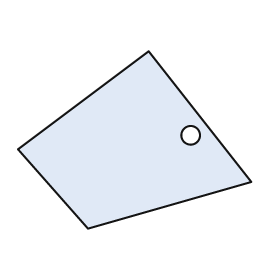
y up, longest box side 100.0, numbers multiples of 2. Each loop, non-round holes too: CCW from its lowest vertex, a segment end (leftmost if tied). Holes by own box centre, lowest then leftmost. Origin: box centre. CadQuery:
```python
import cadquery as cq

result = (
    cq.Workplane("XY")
    .moveTo(-20.0, -38.0)
    .lineTo(50.0, -18.0)
    .lineTo(6.0, 38.0)
    .lineTo(-50.0, -4.0)
    .close()
    .moveTo(24.0, 2.0)
    .circle(4.0)
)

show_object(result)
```